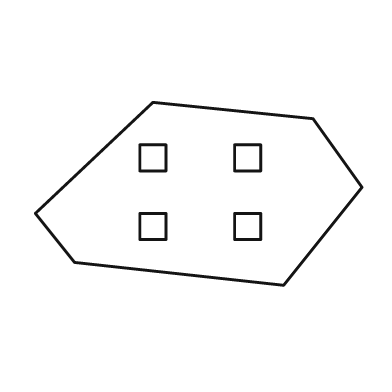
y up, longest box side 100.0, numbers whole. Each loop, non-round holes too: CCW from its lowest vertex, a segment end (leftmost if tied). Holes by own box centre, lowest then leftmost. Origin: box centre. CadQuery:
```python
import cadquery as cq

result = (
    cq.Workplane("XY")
    .moveTo(26.0, -28.0)
    .lineTo(50.0, 2.0)
    .lineTo(35.0, 23.0)
    .lineTo(-14.0, 28.0)
    .lineTo(-50.0, -6.0)
    .lineTo(-38.0, -21.0)
    .close()
    .moveTo(-18.0, -14.0)
    .lineTo(-10.0, -14.0)
    .lineTo(-10.0, -6.0)
    .lineTo(-18.0, -6.0)
    .close()
    .moveTo(11.0, -14.0)
    .lineTo(19.0, -14.0)
    .lineTo(19.0, -6.0)
    .lineTo(11.0, -6.0)
    .close()
    .moveTo(-18.0, 7.0)
    .lineTo(-10.0, 7.0)
    .lineTo(-10.0, 15.0)
    .lineTo(-18.0, 15.0)
    .close()
    .moveTo(11.0, 7.0)
    .lineTo(19.0, 7.0)
    .lineTo(19.0, 15.0)
    .lineTo(11.0, 15.0)
    .close()
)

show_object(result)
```